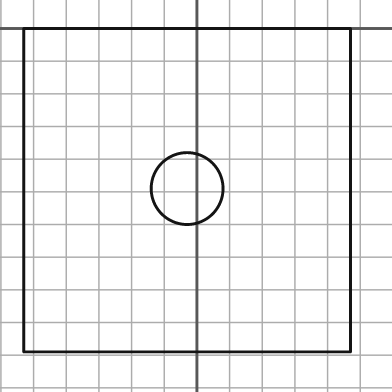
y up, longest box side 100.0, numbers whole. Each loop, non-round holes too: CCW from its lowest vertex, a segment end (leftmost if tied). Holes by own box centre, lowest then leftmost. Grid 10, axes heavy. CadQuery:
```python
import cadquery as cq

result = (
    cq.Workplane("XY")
    .moveTo(-53.0, -99.0)
    .lineTo(47.0, -99.0)
    .lineTo(47.0, 0.0)
    .lineTo(-53.0, 0.0)
    .close()
    .moveTo(-3.0, -49.0)
    .circle(11.0)
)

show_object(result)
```